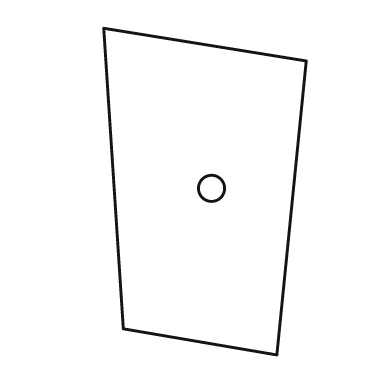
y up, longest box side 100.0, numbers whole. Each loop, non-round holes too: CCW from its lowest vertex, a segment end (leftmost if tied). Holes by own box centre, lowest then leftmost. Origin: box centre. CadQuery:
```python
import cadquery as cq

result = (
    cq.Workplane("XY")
    .moveTo(22.0, -50.0)
    .lineTo(31.0, 40.0)
    .lineTo(-31.0, 50.0)
    .lineTo(-25.0, -42.0)
    .close()
    .moveTo(2.0, 1.0)
    .circle(4.0)
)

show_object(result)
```